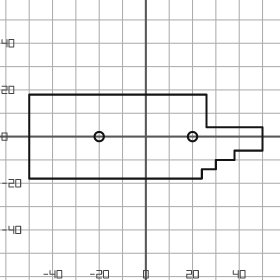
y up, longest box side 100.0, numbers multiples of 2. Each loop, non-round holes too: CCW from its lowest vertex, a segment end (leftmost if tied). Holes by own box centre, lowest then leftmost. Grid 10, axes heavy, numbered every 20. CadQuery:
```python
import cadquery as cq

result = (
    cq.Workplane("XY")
    .moveTo(-50.0, -18.0)
    .lineTo(24.0, -18.0)
    .lineTo(24.0, -14.0)
    .lineTo(30.0, -14.0)
    .lineTo(30.0, -10.0)
    .lineTo(38.0, -10.0)
    .lineTo(38.0, -6.0)
    .lineTo(50.0, -6.0)
    .lineTo(50.0, 4.0)
    .lineTo(26.0, 4.0)
    .lineTo(26.0, 18.0)
    .lineTo(-50.0, 18.0)
    .close()
    .moveTo(-20.0, 0.0)
    .circle(2.0)
    .moveTo(20.0, 0.0)
    .circle(2.0)
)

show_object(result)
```